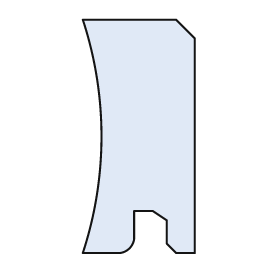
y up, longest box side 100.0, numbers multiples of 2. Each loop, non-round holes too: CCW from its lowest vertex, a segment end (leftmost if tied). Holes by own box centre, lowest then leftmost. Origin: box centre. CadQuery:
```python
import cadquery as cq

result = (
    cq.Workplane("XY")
    .moveTo(-24.0, -50.0)
    .lineTo(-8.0, -50.0)
    .threePointArc((-4.0, -48.0), (-2.0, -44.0))
    .lineTo(-2.0, -32.0)
    .lineTo(6.0, -32.0)
    .lineTo(12.0, -36.0)
    .lineTo(12.0, -46.0)
    .lineTo(16.0, -50.0)
    .lineTo(24.0, -50.0)
    .lineTo(24.0, 42.0)
    .lineTo(16.0, 50.0)
    .lineTo(-24.0, 50.0)
    .threePointArc((-16.0, 0.0), (-24.0, -50.0))
    .close()
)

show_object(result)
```